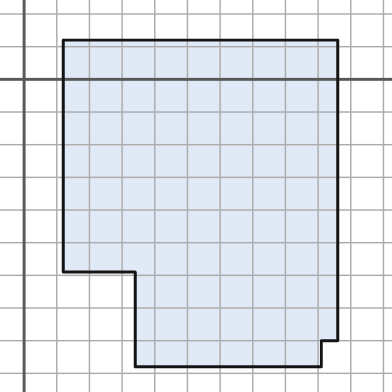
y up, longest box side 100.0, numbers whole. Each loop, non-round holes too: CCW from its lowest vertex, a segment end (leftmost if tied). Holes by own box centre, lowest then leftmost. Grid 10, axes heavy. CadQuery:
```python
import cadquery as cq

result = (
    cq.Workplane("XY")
    .moveTo(34.0, -88.0)
    .lineTo(91.0, -88.0)
    .lineTo(91.0, -80.0)
    .lineTo(96.0, -80.0)
    .lineTo(96.0, 12.0)
    .lineTo(12.0, 12.0)
    .lineTo(12.0, -59.0)
    .lineTo(34.0, -59.0)
    .close()
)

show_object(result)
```